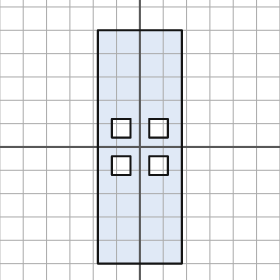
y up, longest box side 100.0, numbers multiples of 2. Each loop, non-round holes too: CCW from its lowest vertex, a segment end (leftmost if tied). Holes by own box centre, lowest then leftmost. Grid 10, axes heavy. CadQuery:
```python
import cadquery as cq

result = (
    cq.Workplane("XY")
    .moveTo(-18.0, -50.0)
    .lineTo(18.0, -50.0)
    .lineTo(18.0, 50.0)
    .lineTo(-18.0, 50.0)
    .close()
    .moveTo(-12.0, -12.0)
    .lineTo(-4.0, -12.0)
    .lineTo(-4.0, -4.0)
    .lineTo(-12.0, -4.0)
    .close()
    .moveTo(4.0, -12.0)
    .lineTo(12.0, -12.0)
    .lineTo(12.0, -4.0)
    .lineTo(4.0, -4.0)
    .close()
    .moveTo(-12.0, 4.0)
    .lineTo(-4.0, 4.0)
    .lineTo(-4.0, 12.0)
    .lineTo(-12.0, 12.0)
    .close()
    .moveTo(4.0, 4.0)
    .lineTo(12.0, 4.0)
    .lineTo(12.0, 12.0)
    .lineTo(4.0, 12.0)
    .close()
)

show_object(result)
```